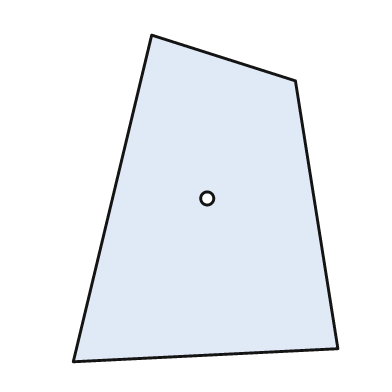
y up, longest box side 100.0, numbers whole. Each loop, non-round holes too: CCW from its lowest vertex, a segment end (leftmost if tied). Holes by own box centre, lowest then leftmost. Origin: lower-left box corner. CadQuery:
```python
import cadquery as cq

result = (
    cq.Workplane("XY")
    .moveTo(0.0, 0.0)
    .lineTo(81.0, 4.0)
    .lineTo(68.0, 86.0)
    .lineTo(24.0, 100.0)
    .close()
    .moveTo(41.0, 50.0)
    .circle(2.0)
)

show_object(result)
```